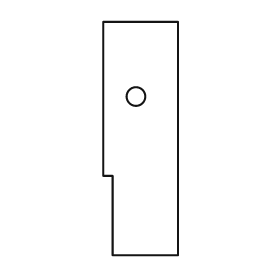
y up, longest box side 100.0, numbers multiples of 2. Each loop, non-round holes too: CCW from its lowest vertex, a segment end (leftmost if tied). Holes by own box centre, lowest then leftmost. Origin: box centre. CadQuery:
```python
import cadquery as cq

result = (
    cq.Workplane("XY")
    .moveTo(-12.0, -50.0)
    .lineTo(16.0, -50.0)
    .lineTo(16.0, 50.0)
    .lineTo(-16.0, 50.0)
    .lineTo(-16.0, -16.0)
    .lineTo(-12.0, -16.0)
    .close()
    .moveTo(-2.0, 18.0)
    .circle(4.0)
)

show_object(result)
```